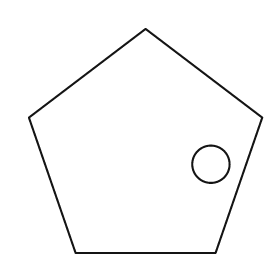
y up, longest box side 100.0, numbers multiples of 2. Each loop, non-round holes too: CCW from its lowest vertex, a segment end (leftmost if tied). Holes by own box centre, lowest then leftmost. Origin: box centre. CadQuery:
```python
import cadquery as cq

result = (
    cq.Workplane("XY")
    .moveTo(-30.0, -48.0)
    .lineTo(30.0, -48.0)
    .lineTo(50.0, 10.0)
    .lineTo(0.0, 48.0)
    .lineTo(-50.0, 10.0)
    .close()
    .moveTo(28.0, -10.0)
    .circle(8.0)
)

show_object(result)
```